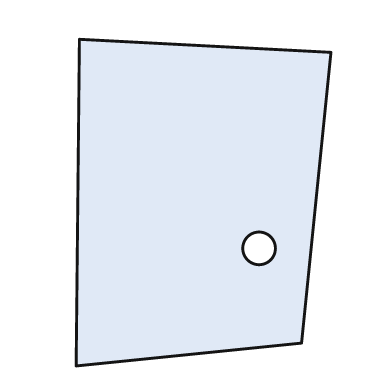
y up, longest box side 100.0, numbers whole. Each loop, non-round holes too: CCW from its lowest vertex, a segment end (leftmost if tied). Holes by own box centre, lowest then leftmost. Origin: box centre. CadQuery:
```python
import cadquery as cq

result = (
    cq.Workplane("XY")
    .moveTo(-39.0, -50.0)
    .lineTo(30.0, -43.0)
    .lineTo(39.0, 46.0)
    .lineTo(-38.0, 50.0)
    .close()
    .moveTo(17.0, -14.0)
    .circle(5.0)
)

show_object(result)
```